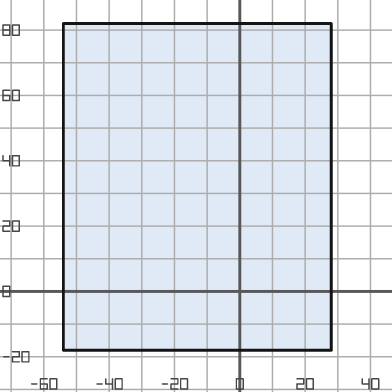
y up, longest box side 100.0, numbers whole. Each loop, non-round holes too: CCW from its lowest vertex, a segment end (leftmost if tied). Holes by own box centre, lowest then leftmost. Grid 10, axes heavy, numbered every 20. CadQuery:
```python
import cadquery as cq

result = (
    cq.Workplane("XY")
    .moveTo(-54.0, -18.0)
    .lineTo(28.0, -18.0)
    .lineTo(28.0, 82.0)
    .lineTo(-54.0, 82.0)
    .close()
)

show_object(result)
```